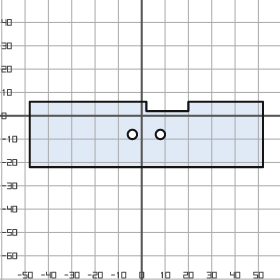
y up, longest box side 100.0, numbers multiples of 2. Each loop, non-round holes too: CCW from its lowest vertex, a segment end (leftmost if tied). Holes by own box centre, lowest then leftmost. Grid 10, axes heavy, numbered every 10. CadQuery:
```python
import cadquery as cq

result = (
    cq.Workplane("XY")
    .moveTo(-48.0, -22.0)
    .lineTo(52.0, -22.0)
    .lineTo(52.0, 6.0)
    .lineTo(20.0, 6.0)
    .lineTo(20.0, 2.0)
    .lineTo(2.0, 2.0)
    .lineTo(2.0, 6.0)
    .lineTo(-48.0, 6.0)
    .close()
    .moveTo(-4.0, -8.0)
    .circle(2.0)
    .moveTo(8.0, -8.0)
    .circle(2.0)
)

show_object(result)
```